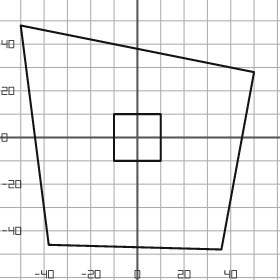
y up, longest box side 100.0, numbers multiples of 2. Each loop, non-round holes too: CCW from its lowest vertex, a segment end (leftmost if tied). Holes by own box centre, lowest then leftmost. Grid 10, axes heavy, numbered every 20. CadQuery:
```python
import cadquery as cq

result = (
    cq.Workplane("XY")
    .moveTo(36.0, -48.0)
    .lineTo(50.0, 28.0)
    .lineTo(-50.0, 48.0)
    .lineTo(-38.0, -46.0)
    .close()
    .moveTo(-10.0, -10.0)
    .lineTo(10.0, -10.0)
    .lineTo(10.0, 10.0)
    .lineTo(-10.0, 10.0)
    .close()
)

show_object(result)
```